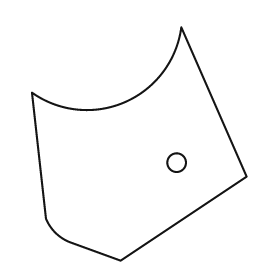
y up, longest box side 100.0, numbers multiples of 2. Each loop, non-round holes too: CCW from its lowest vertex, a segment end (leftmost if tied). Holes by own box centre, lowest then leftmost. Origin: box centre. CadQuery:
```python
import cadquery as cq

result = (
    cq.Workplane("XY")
    .moveTo(-8.0, -50.0)
    .lineTo(46.0, -14.0)
    .lineTo(18.0, 50.0)
    .threePointArc((-6.0, 18.0), (-46.0, 22.0))
    .lineTo(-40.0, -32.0)
    .threePointArc((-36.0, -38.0), (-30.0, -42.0))
    .close()
    .moveTo(16.0, -8.0)
    .circle(4.0)
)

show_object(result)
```